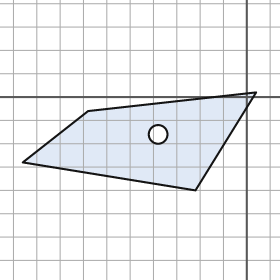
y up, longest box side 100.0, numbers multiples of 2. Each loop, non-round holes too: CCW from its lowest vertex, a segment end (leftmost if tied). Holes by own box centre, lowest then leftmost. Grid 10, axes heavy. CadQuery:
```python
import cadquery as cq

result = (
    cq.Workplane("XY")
    .moveTo(-22.0, -40.0)
    .lineTo(4.0, 2.0)
    .lineTo(-68.0, -6.0)
    .lineTo(-96.0, -28.0)
    .close()
    .moveTo(-38.0, -16.0)
    .circle(4.0)
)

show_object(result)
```